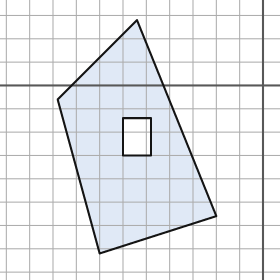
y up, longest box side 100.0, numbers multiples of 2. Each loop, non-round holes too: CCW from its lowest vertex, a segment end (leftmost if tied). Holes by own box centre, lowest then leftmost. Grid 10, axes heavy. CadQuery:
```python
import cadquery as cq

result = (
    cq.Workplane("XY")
    .moveTo(-70.0, -72.0)
    .lineTo(-20.0, -56.0)
    .lineTo(-54.0, 28.0)
    .lineTo(-88.0, -6.0)
    .close()
    .moveTo(-60.0, -30.0)
    .lineTo(-48.0, -30.0)
    .lineTo(-48.0, -14.0)
    .lineTo(-60.0, -14.0)
    .close()
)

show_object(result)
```